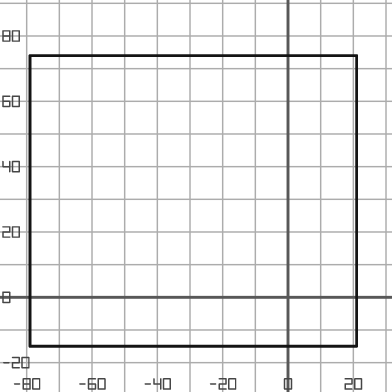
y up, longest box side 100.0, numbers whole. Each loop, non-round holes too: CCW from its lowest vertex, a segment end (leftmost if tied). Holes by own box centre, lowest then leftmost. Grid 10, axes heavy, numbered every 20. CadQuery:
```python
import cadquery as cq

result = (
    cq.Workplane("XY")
    .moveTo(-79.0, -15.0)
    .lineTo(21.0, -15.0)
    .lineTo(21.0, 74.0)
    .lineTo(-79.0, 74.0)
    .close()
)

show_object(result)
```